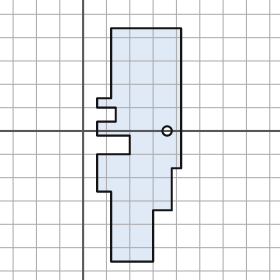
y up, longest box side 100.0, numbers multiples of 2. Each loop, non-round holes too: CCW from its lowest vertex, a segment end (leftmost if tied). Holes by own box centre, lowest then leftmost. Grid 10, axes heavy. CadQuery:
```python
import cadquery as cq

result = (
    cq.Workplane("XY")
    .moveTo(12.0, -56.0)
    .lineTo(30.0, -56.0)
    .lineTo(30.0, -34.0)
    .lineTo(38.0, -34.0)
    .lineTo(38.0, -16.0)
    .lineTo(42.0, -16.0)
    .lineTo(42.0, 44.0)
    .lineTo(12.0, 44.0)
    .lineTo(12.0, 14.0)
    .lineTo(6.0, 14.0)
    .lineTo(6.0, 10.0)
    .lineTo(14.0, 10.0)
    .lineTo(14.0, 4.0)
    .lineTo(6.0, 4.0)
    .lineTo(6.0, -2.0)
    .lineTo(20.0, -2.0)
    .lineTo(20.0, -10.0)
    .lineTo(6.0, -10.0)
    .lineTo(6.0, -26.0)
    .lineTo(12.0, -26.0)
    .close()
    .moveTo(36.0, 0.0)
    .circle(2.0)
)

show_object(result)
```